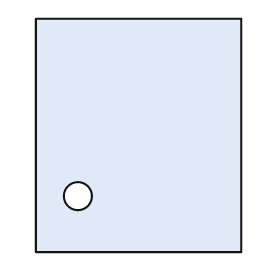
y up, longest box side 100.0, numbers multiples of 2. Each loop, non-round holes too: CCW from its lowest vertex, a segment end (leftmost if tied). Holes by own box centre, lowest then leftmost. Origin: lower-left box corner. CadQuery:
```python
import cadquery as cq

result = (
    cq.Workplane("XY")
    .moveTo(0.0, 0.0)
    .lineTo(88.0, 0.0)
    .lineTo(88.0, 100.0)
    .lineTo(0.0, 100.0)
    .close()
    .moveTo(18.0, 24.0)
    .circle(6.0)
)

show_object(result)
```